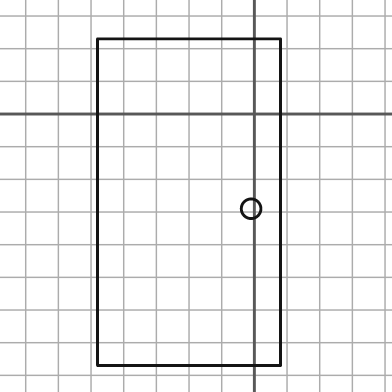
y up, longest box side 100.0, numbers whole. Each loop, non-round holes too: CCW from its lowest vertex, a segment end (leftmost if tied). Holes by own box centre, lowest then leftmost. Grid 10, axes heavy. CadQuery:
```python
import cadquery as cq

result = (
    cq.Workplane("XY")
    .moveTo(-48.0, -77.0)
    .lineTo(8.0, -77.0)
    .lineTo(8.0, 23.0)
    .lineTo(-48.0, 23.0)
    .close()
    .moveTo(-1.0, -29.0)
    .circle(3.0)
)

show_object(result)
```